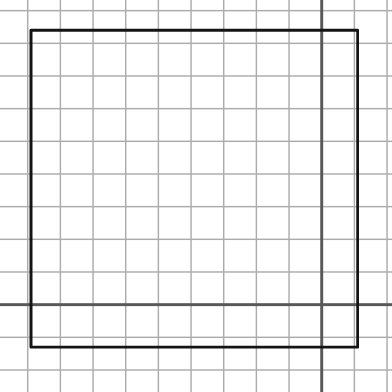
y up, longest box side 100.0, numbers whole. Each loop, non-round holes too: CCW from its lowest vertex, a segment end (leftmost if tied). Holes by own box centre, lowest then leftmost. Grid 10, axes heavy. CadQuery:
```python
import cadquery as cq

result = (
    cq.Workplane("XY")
    .moveTo(-89.0, -13.0)
    .lineTo(11.0, -13.0)
    .lineTo(11.0, 84.0)
    .lineTo(-89.0, 84.0)
    .close()
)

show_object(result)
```